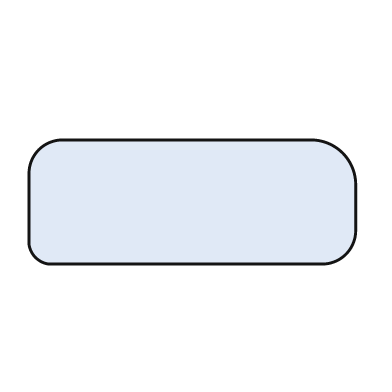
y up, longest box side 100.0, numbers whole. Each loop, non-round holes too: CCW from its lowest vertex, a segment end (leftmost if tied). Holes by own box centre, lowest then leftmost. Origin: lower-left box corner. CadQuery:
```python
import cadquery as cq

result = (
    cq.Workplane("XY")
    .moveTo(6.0, 0.0)
    .lineTo(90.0, 0.0)
    .threePointArc((97.0, 3.0), (100.0, 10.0))
    .lineTo(100.0, 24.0)
    .threePointArc((96.0, 34.0), (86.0, 38.0))
    .lineTo(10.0, 38.0)
    .threePointArc((3.0, 35.0), (0.0, 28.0))
    .lineTo(0.0, 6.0)
    .threePointArc((2.0, 2.0), (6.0, 0.0))
    .close()
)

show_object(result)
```